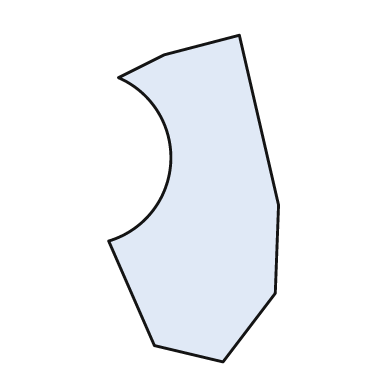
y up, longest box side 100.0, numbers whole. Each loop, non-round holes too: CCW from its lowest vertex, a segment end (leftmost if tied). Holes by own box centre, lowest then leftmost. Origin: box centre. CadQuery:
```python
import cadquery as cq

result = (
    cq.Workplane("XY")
    .moveTo(9.0, -50.0)
    .lineTo(25.0, -29.0)
    .lineTo(26.0, -2.0)
    .lineTo(14.0, 50.0)
    .lineTo(-9.0, 44.0)
    .lineTo(-23.0, 37.0)
    .threePointArc((-7.0, 11.0), (-26.0, -13.0))
    .lineTo(-12.0, -45.0)
    .close()
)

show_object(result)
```